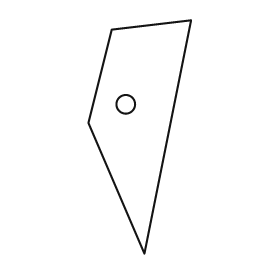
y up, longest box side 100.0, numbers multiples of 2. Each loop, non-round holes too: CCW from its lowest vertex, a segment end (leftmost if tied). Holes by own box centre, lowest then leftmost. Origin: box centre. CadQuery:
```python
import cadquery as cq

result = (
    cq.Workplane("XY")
    .moveTo(2.0, -50.0)
    .lineTo(22.0, 50.0)
    .lineTo(-12.0, 46.0)
    .lineTo(-22.0, 6.0)
    .close()
    .moveTo(-6.0, 14.0)
    .circle(4.0)
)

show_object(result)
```